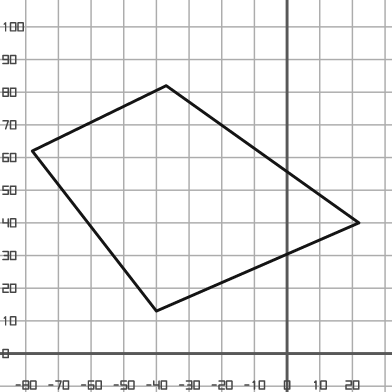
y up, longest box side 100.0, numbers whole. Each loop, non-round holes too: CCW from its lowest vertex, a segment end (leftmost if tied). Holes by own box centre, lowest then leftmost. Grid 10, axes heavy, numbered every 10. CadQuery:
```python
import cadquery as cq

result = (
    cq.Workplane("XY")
    .moveTo(-40.0, 13.0)
    .lineTo(22.0, 40.0)
    .lineTo(-37.0, 82.0)
    .lineTo(-78.0, 62.0)
    .close()
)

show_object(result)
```